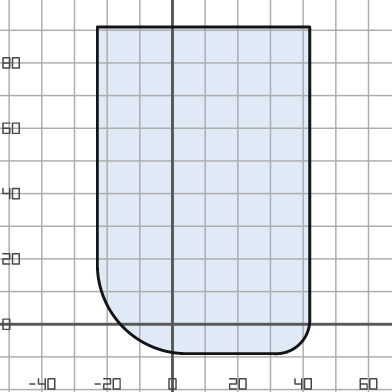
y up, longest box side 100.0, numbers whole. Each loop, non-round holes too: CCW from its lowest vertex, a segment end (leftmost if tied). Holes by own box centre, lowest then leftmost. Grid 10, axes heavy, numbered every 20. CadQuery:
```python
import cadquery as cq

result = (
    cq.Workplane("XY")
    .moveTo(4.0, -9.0)
    .lineTo(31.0, -9.0)
    .threePointArc((39.0, -6.0), (42.0, 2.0))
    .lineTo(42.0, 91.0)
    .lineTo(-23.0, 91.0)
    .lineTo(-23.0, 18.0)
    .threePointArc((-15.0, -1.0), (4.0, -9.0))
    .close()
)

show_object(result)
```